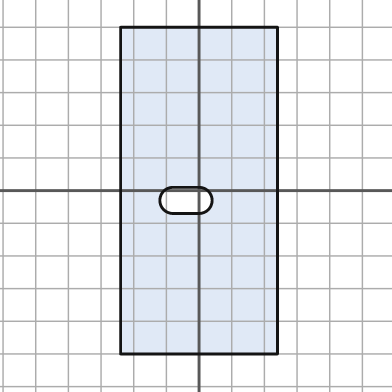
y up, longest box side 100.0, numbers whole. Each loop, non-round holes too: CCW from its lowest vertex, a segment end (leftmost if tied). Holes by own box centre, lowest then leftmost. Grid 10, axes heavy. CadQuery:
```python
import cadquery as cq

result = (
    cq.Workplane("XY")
    .moveTo(-24.0, -50.0)
    .lineTo(24.0, -50.0)
    .lineTo(24.0, 50.0)
    .lineTo(-24.0, 50.0)
    .close()
    .moveTo(-8.0, -7.0)
    .lineTo(0.0, -7.0)
    .threePointArc((4.0, -3.0), (0.0, 1.0))
    .lineTo(-8.0, 1.0)
    .threePointArc((-12.0, -3.0), (-8.0, -7.0))
    .close()
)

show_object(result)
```